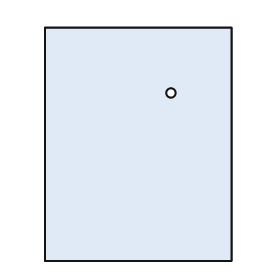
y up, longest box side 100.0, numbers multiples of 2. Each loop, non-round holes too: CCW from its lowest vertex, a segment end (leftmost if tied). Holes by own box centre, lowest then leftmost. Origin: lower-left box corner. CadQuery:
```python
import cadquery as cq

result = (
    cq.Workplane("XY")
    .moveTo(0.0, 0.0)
    .lineTo(80.0, 0.0)
    .lineTo(80.0, 100.0)
    .lineTo(0.0, 100.0)
    .close()
    .moveTo(54.0, 72.0)
    .circle(2.0)
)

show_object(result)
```